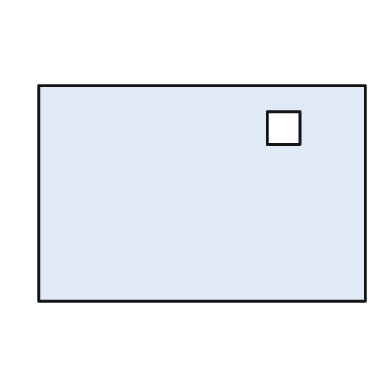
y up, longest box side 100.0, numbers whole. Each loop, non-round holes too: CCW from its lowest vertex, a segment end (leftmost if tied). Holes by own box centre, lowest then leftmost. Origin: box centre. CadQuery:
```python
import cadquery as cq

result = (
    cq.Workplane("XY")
    .moveTo(-50.0, -33.0)
    .lineTo(50.0, -33.0)
    .lineTo(50.0, 33.0)
    .lineTo(-50.0, 33.0)
    .close()
    .moveTo(20.0, 15.0)
    .lineTo(30.0, 15.0)
    .lineTo(30.0, 25.0)
    .lineTo(20.0, 25.0)
    .close()
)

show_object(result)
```